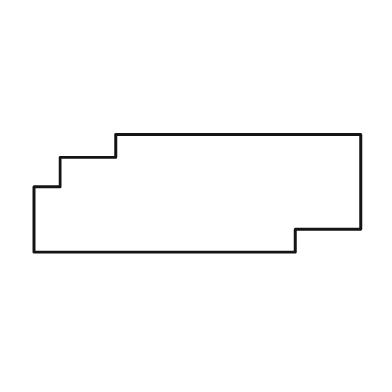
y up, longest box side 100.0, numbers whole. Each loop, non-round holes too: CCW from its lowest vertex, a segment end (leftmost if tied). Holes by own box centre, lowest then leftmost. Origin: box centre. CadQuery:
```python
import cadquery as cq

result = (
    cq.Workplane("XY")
    .moveTo(-50.0, -18.0)
    .lineTo(30.0, -18.0)
    .lineTo(30.0, -11.0)
    .lineTo(50.0, -11.0)
    .lineTo(50.0, 18.0)
    .lineTo(-25.0, 18.0)
    .lineTo(-25.0, 11.0)
    .lineTo(-42.0, 11.0)
    .lineTo(-42.0, 2.0)
    .lineTo(-50.0, 2.0)
    .close()
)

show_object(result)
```